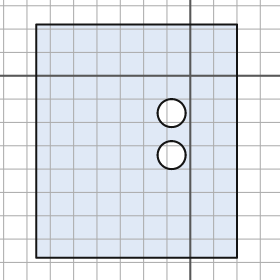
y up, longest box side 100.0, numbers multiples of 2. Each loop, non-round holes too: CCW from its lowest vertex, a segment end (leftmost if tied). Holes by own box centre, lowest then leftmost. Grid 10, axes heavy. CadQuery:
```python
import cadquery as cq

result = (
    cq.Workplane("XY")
    .moveTo(-66.0, -78.0)
    .lineTo(20.0, -78.0)
    .lineTo(20.0, 22.0)
    .lineTo(-66.0, 22.0)
    .close()
    .moveTo(-8.0, -34.0)
    .circle(6.0)
    .moveTo(-8.0, -16.0)
    .circle(6.0)
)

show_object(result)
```